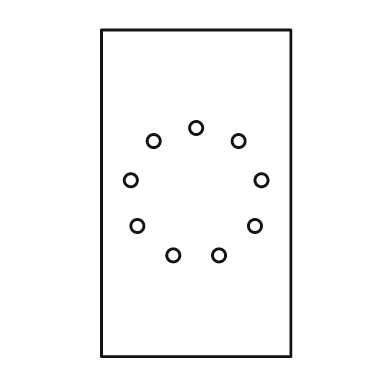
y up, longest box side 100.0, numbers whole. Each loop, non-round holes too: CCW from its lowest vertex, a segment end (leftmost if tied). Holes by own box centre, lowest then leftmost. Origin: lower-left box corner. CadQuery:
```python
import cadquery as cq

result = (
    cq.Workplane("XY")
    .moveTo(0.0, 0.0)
    .lineTo(58.0, 0.0)
    .lineTo(58.0, 100.0)
    .lineTo(0.0, 100.0)
    .close()
    .moveTo(22.0, 31.0)
    .circle(2.0)
    .moveTo(36.0, 31.0)
    .circle(2.0)
    .moveTo(11.0, 40.0)
    .circle(2.0)
    .moveTo(47.0, 40.0)
    .circle(2.0)
    .moveTo(9.0, 54.0)
    .circle(2.0)
    .moveTo(49.0, 54.0)
    .circle(2.0)
    .moveTo(16.0, 66.0)
    .circle(2.0)
    .moveTo(42.0, 66.0)
    .circle(2.0)
    .moveTo(29.0, 70.0)
    .circle(2.0)
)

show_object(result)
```